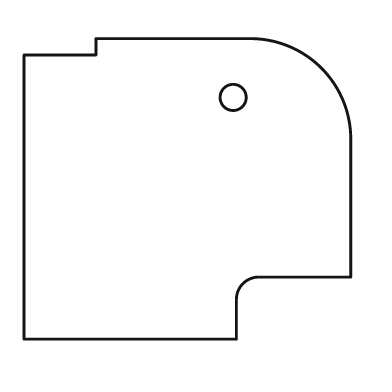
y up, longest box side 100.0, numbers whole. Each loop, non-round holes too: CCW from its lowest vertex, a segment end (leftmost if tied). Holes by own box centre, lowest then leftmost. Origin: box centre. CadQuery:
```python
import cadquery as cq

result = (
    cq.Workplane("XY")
    .moveTo(-50.0, -46.0)
    .lineTo(15.0, -46.0)
    .lineTo(15.0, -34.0)
    .threePointArc((17.0, -29.0), (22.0, -27.0))
    .lineTo(50.0, -27.0)
    .lineTo(50.0, 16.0)
    .threePointArc((41.0, 37.0), (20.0, 46.0))
    .lineTo(-28.0, 46.0)
    .lineTo(-28.0, 41.0)
    .lineTo(-50.0, 41.0)
    .close()
    .moveTo(14.0, 28.0)
    .circle(4.0)
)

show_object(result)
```